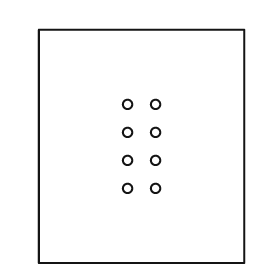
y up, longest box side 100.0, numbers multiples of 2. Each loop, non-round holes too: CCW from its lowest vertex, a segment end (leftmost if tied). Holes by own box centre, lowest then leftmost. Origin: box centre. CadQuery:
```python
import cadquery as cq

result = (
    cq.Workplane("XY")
    .moveTo(-44.0, -50.0)
    .lineTo(44.0, -50.0)
    .lineTo(44.0, 50.0)
    .lineTo(-44.0, 50.0)
    .close()
    .moveTo(-6.0, -18.0)
    .circle(2.0)
    .moveTo(6.0, -18.0)
    .circle(2.0)
    .moveTo(-6.0, -6.0)
    .circle(2.0)
    .moveTo(6.0, -6.0)
    .circle(2.0)
    .moveTo(-6.0, 6.0)
    .circle(2.0)
    .moveTo(6.0, 6.0)
    .circle(2.0)
    .moveTo(-6.0, 18.0)
    .circle(2.0)
    .moveTo(6.0, 18.0)
    .circle(2.0)
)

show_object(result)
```